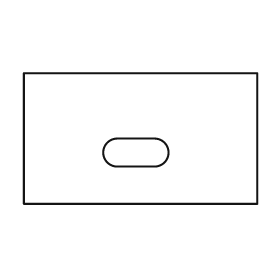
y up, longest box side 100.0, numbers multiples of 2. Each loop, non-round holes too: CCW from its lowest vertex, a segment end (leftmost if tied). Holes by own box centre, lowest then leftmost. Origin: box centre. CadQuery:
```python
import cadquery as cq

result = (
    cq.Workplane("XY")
    .moveTo(-50.0, -28.0)
    .lineTo(50.0, -28.0)
    .lineTo(50.0, 28.0)
    .lineTo(-50.0, 28.0)
    .close()
    .moveTo(-10.0, -12.0)
    .lineTo(6.0, -12.0)
    .threePointArc((12.0, -6.0), (6.0, 0.0))
    .lineTo(-10.0, 0.0)
    .threePointArc((-16.0, -6.0), (-10.0, -12.0))
    .close()
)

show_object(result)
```